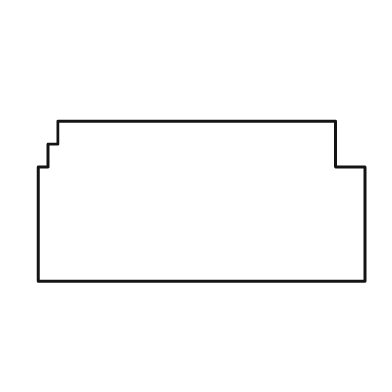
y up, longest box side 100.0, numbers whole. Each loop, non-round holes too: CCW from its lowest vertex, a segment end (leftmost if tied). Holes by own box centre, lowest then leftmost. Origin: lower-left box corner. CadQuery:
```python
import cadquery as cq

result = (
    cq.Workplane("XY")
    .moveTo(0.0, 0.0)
    .lineTo(100.0, 0.0)
    .lineTo(100.0, 35.0)
    .lineTo(91.0, 35.0)
    .lineTo(91.0, 49.0)
    .lineTo(6.0, 49.0)
    .lineTo(6.0, 42.0)
    .lineTo(3.0, 42.0)
    .lineTo(3.0, 35.0)
    .lineTo(0.0, 35.0)
    .close()
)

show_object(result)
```